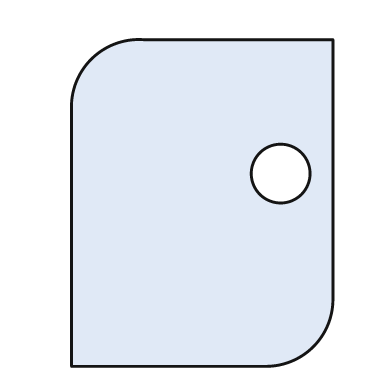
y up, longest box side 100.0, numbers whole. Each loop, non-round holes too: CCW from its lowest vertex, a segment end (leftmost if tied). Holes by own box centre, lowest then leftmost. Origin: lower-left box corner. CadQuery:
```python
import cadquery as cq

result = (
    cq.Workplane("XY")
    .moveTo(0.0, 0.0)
    .lineTo(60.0, 0.0)
    .threePointArc((74.0, 6.0), (80.0, 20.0))
    .lineTo(80.0, 100.0)
    .lineTo(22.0, 100.0)
    .threePointArc((6.0, 94.0), (0.0, 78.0))
    .close()
    .moveTo(64.0, 59.0)
    .circle(9.0)
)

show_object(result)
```